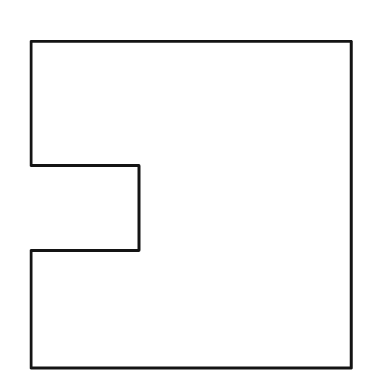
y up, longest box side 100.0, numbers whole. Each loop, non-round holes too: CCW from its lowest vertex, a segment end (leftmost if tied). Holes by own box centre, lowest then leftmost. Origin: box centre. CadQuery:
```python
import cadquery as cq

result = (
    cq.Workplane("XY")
    .moveTo(-49.0, -50.0)
    .lineTo(49.0, -50.0)
    .lineTo(49.0, 50.0)
    .lineTo(-49.0, 50.0)
    .lineTo(-49.0, 12.0)
    .lineTo(-16.0, 12.0)
    .lineTo(-16.0, -14.0)
    .lineTo(-49.0, -14.0)
    .close()
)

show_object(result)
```